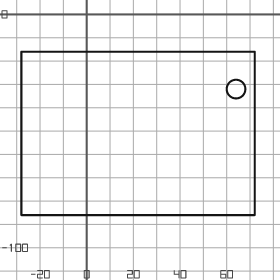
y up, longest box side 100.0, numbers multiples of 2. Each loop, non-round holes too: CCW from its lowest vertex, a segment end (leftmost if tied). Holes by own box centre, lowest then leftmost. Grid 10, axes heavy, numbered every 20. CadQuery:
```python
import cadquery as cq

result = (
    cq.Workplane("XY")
    .moveTo(-28.0, -86.0)
    .lineTo(72.0, -86.0)
    .lineTo(72.0, -16.0)
    .lineTo(-28.0, -16.0)
    .close()
    .moveTo(64.0, -32.0)
    .circle(4.0)
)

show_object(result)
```